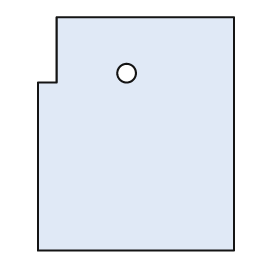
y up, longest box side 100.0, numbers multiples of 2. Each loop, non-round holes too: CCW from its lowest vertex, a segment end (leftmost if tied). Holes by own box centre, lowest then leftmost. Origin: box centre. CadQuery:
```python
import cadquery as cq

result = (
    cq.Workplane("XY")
    .moveTo(-42.0, -50.0)
    .lineTo(42.0, -50.0)
    .lineTo(42.0, 50.0)
    .lineTo(-34.0, 50.0)
    .lineTo(-34.0, 22.0)
    .lineTo(-42.0, 22.0)
    .close()
    .moveTo(-4.0, 26.0)
    .circle(4.0)
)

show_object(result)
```